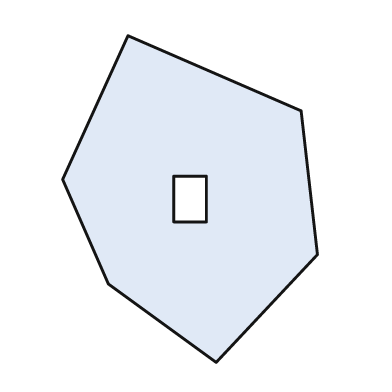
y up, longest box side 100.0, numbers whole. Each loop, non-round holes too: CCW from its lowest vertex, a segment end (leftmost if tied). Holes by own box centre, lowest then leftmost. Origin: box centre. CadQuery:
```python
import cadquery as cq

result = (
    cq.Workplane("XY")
    .moveTo(8.0, -50.0)
    .lineTo(39.0, -17.0)
    .lineTo(34.0, 27.0)
    .lineTo(-19.0, 50.0)
    .lineTo(-39.0, 6.0)
    .lineTo(-25.0, -26.0)
    .close()
    .moveTo(-5.0, -7.0)
    .lineTo(5.0, -7.0)
    .lineTo(5.0, 7.0)
    .lineTo(-5.0, 7.0)
    .close()
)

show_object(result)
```